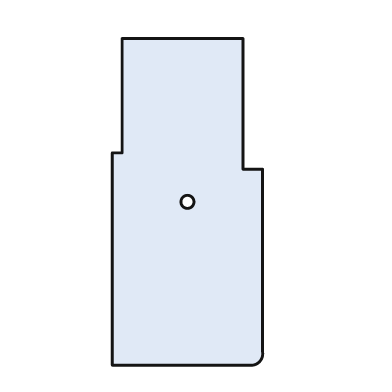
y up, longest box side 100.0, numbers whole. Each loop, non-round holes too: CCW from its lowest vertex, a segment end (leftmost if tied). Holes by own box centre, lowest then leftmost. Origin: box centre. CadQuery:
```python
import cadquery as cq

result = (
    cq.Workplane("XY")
    .moveTo(-23.0, -50.0)
    .lineTo(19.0, -50.0)
    .threePointArc((22.0, -49.0), (23.0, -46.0))
    .lineTo(23.0, 10.0)
    .lineTo(17.0, 10.0)
    .lineTo(17.0, 50.0)
    .lineTo(-20.0, 50.0)
    .lineTo(-20.0, 15.0)
    .lineTo(-23.0, 15.0)
    .close()
    .moveTo(0.0, 0.0)
    .circle(2.0)
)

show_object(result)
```